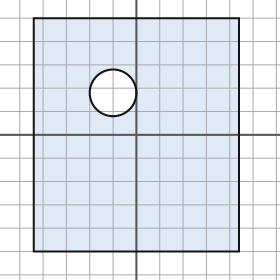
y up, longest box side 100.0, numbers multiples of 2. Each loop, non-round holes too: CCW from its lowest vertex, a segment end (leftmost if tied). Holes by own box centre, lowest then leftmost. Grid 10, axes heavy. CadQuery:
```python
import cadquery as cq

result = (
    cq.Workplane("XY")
    .moveTo(-44.0, -50.0)
    .lineTo(44.0, -50.0)
    .lineTo(44.0, 50.0)
    .lineTo(-44.0, 50.0)
    .close()
    .moveTo(-10.0, 18.0)
    .circle(10.0)
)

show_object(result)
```